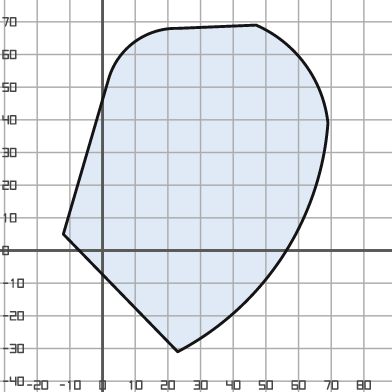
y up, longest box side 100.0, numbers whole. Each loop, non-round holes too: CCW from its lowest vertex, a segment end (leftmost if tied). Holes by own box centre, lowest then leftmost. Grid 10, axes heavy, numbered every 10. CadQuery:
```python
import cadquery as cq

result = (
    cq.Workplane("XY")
    .moveTo(23.0, -31.0)
    .threePointArc((55.0, -2.0), (69.0, 39.0))
    .threePointArc((62.0, 57.0), (47.0, 69.0))
    .lineTo(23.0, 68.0)
    .threePointArc((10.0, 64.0), (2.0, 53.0))
    .lineTo(-12.0, 5.0)
    .close()
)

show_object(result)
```